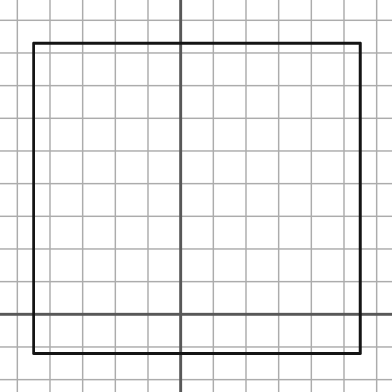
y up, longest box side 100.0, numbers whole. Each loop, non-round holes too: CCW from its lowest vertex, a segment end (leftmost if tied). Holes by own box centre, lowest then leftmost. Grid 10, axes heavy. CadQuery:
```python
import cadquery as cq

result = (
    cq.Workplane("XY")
    .moveTo(-45.0, -12.0)
    .lineTo(55.0, -12.0)
    .lineTo(55.0, 83.0)
    .lineTo(-45.0, 83.0)
    .close()
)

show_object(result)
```